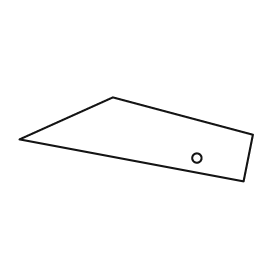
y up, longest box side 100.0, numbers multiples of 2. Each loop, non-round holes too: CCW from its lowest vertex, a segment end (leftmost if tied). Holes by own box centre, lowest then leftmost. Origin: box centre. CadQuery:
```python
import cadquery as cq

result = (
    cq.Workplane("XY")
    .moveTo(46.0, -18.0)
    .lineTo(50.0, 2.0)
    .lineTo(-10.0, 18.0)
    .lineTo(-50.0, 0.0)
    .close()
    .moveTo(26.0, -8.0)
    .circle(2.0)
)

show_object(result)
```